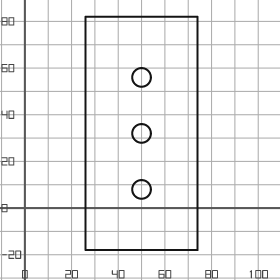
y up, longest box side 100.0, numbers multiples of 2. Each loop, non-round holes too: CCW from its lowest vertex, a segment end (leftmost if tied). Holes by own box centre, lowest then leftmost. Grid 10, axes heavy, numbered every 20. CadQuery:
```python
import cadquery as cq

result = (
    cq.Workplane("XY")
    .moveTo(26.0, -18.0)
    .lineTo(74.0, -18.0)
    .lineTo(74.0, 82.0)
    .lineTo(26.0, 82.0)
    .close()
    .moveTo(50.0, 8.0)
    .circle(4.0)
    .moveTo(50.0, 32.0)
    .circle(4.0)
    .moveTo(50.0, 56.0)
    .circle(4.0)
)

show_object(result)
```